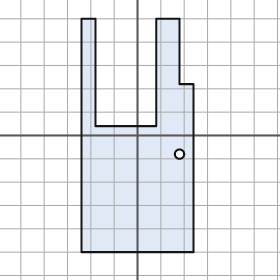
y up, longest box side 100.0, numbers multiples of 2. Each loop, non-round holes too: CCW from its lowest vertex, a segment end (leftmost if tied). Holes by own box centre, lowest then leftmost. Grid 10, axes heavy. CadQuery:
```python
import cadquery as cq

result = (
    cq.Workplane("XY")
    .moveTo(-24.0, -50.0)
    .lineTo(24.0, -50.0)
    .lineTo(24.0, 22.0)
    .lineTo(18.0, 22.0)
    .lineTo(18.0, 50.0)
    .lineTo(8.0, 50.0)
    .lineTo(8.0, 4.0)
    .lineTo(-18.0, 4.0)
    .lineTo(-18.0, 50.0)
    .lineTo(-24.0, 50.0)
    .close()
    .moveTo(18.0, -8.0)
    .circle(2.0)
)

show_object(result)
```